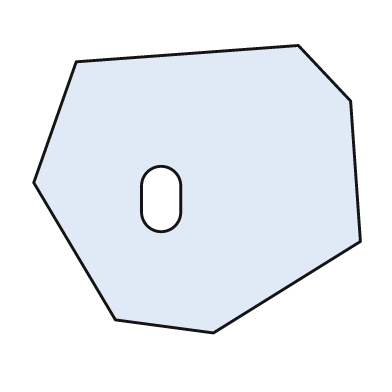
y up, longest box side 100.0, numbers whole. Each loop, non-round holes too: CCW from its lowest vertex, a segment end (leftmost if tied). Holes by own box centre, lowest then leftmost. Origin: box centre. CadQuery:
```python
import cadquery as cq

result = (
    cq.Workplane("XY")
    .moveTo(5.0, -44.0)
    .lineTo(50.0, -16.0)
    .lineTo(47.0, 27.0)
    .lineTo(31.0, 44.0)
    .lineTo(-37.0, 39.0)
    .lineTo(-50.0, 2.0)
    .lineTo(-25.0, -40.0)
    .close()
    .moveTo(-17.0, -7.0)
    .threePointArc((-11.0, -13.0), (-5.0, -7.0))
    .lineTo(-5.0, 1.0)
    .threePointArc((-11.0, 7.0), (-17.0, 1.0))
    .close()
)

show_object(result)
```